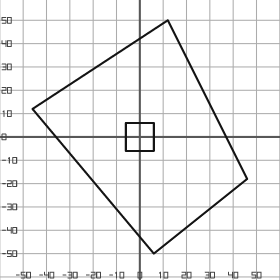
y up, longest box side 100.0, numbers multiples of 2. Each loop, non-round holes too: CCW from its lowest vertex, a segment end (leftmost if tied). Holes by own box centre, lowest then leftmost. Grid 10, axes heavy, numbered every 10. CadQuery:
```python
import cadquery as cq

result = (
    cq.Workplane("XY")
    .moveTo(6.0, -50.0)
    .lineTo(46.0, -18.0)
    .lineTo(12.0, 50.0)
    .lineTo(-46.0, 12.0)
    .close()
    .moveTo(-6.0, -6.0)
    .lineTo(6.0, -6.0)
    .lineTo(6.0, 6.0)
    .lineTo(-6.0, 6.0)
    .close()
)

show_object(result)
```